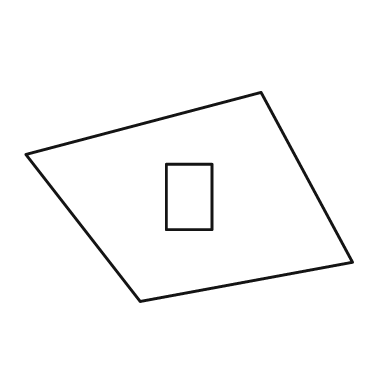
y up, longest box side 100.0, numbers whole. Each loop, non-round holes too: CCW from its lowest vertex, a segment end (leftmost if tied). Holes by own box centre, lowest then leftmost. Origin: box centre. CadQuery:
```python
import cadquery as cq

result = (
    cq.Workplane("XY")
    .moveTo(-15.0, -32.0)
    .lineTo(50.0, -20.0)
    .lineTo(22.0, 32.0)
    .lineTo(-50.0, 13.0)
    .close()
    .moveTo(-7.0, -10.0)
    .lineTo(7.0, -10.0)
    .lineTo(7.0, 10.0)
    .lineTo(-7.0, 10.0)
    .close()
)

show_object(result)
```